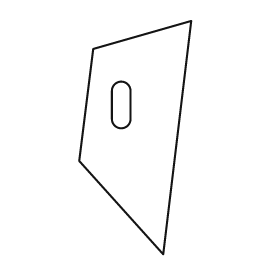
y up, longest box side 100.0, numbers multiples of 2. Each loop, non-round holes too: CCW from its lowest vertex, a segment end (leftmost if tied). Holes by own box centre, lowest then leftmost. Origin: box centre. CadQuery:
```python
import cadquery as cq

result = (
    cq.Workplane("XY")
    .moveTo(12.0, -50.0)
    .lineTo(24.0, 50.0)
    .lineTo(-18.0, 38.0)
    .lineTo(-24.0, -10.0)
    .close()
    .moveTo(-10.0, 8.0)
    .threePointArc((-6.0, 4.0), (-2.0, 8.0))
    .lineTo(-2.0, 20.0)
    .threePointArc((-6.0, 24.0), (-10.0, 20.0))
    .close()
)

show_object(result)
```